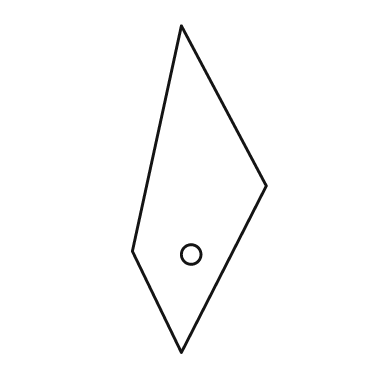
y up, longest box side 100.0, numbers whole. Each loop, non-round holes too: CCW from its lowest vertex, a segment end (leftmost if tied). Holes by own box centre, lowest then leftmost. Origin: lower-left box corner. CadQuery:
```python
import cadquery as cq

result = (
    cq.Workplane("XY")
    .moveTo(15.0, 0.0)
    .lineTo(41.0, 51.0)
    .lineTo(15.0, 100.0)
    .lineTo(0.0, 31.0)
    .close()
    .moveTo(18.0, 30.0)
    .circle(3.0)
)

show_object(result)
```